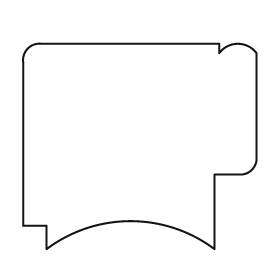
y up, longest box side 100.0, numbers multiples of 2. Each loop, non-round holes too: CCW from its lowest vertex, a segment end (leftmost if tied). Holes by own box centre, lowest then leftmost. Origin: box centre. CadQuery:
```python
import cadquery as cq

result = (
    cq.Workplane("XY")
    .moveTo(-40.0, -44.0)
    .threePointArc((-4.0, -32.0), (32.0, -44.0))
    .lineTo(32.0, -12.0)
    .lineTo(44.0, -12.0)
    .threePointArc((48.0, -10.0), (50.0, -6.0))
    .lineTo(50.0, 40.0)
    .threePointArc((42.0, 44.0), (34.0, 40.0))
    .lineTo(34.0, 44.0)
    .lineTo(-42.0, 44.0)
    .threePointArc((-48.0, 42.0), (-50.0, 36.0))
    .lineTo(-50.0, -34.0)
    .lineTo(-40.0, -34.0)
    .close()
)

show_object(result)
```